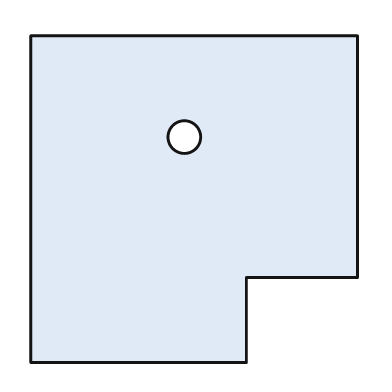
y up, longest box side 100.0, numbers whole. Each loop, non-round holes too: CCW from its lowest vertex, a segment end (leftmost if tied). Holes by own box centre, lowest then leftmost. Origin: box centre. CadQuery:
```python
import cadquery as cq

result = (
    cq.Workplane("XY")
    .moveTo(-50.0, -50.0)
    .lineTo(16.0, -50.0)
    .lineTo(16.0, -24.0)
    .lineTo(50.0, -24.0)
    .lineTo(50.0, 50.0)
    .lineTo(-50.0, 50.0)
    .close()
    .moveTo(-3.0, 19.0)
    .circle(5.0)
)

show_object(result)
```